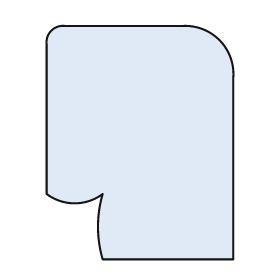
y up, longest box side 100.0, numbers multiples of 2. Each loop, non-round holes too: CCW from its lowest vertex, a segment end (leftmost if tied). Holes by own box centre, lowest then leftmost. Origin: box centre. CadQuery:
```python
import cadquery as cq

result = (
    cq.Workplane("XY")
    .moveTo(-16.0, -50.0)
    .lineTo(40.0, -50.0)
    .lineTo(40.0, 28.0)
    .threePointArc((34.0, 44.0), (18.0, 50.0))
    .lineTo(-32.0, 50.0)
    .threePointArc((-38.0, 48.0), (-40.0, 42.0))
    .lineTo(-40.0, -22.0)
    .threePointArc((-28.0, -26.0), (-16.0, -22.0))
    .threePointArc((-18.0, -36.0), (-16.0, -50.0))
    .close()
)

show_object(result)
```